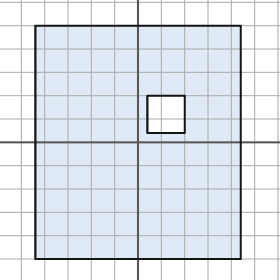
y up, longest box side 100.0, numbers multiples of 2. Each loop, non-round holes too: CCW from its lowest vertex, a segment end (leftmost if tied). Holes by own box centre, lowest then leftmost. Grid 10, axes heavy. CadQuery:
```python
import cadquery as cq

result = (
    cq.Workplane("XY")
    .moveTo(-44.0, -50.0)
    .lineTo(44.0, -50.0)
    .lineTo(44.0, 50.0)
    .lineTo(-44.0, 50.0)
    .close()
    .moveTo(4.0, 4.0)
    .lineTo(20.0, 4.0)
    .lineTo(20.0, 20.0)
    .lineTo(4.0, 20.0)
    .close()
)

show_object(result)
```